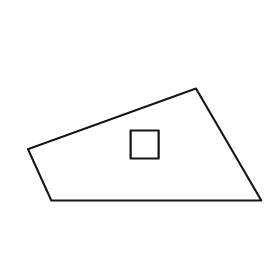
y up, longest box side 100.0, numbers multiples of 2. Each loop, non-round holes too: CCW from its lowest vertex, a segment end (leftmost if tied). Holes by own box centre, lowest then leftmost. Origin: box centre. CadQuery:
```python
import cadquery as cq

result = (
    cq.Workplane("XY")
    .moveTo(-40.0, -24.0)
    .lineTo(50.0, -24.0)
    .lineTo(22.0, 24.0)
    .lineTo(-50.0, -2.0)
    .close()
    .moveTo(-6.0, -6.0)
    .lineTo(6.0, -6.0)
    .lineTo(6.0, 6.0)
    .lineTo(-6.0, 6.0)
    .close()
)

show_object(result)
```